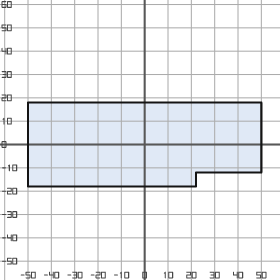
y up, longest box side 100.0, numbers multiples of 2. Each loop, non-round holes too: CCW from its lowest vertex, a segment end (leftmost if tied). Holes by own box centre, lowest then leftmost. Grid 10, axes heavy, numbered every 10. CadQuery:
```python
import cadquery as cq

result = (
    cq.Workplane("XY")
    .moveTo(-50.0, -18.0)
    .lineTo(22.0, -18.0)
    .lineTo(22.0, -12.0)
    .lineTo(50.0, -12.0)
    .lineTo(50.0, 18.0)
    .lineTo(-50.0, 18.0)
    .close()
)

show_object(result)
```